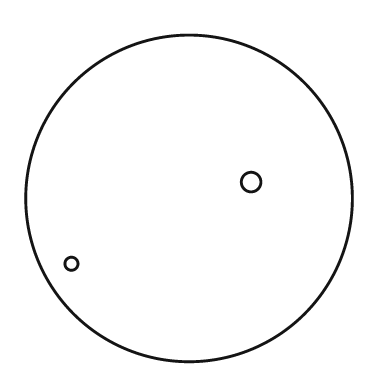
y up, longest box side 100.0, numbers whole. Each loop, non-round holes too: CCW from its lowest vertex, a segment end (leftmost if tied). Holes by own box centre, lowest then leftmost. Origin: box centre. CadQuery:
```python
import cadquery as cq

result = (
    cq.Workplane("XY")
    .moveTo(0.0, 0.0)
    .circle(50.0)
    .moveTo(-36.0, -20.0)
    .circle(2.0)
    .moveTo(19.0, 5.0)
    .circle(3.0)
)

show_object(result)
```